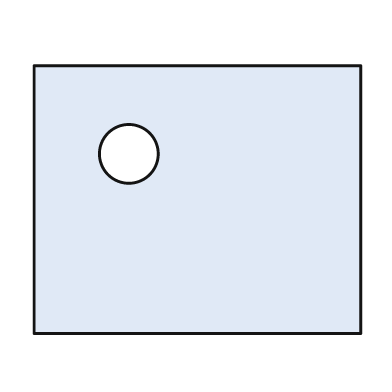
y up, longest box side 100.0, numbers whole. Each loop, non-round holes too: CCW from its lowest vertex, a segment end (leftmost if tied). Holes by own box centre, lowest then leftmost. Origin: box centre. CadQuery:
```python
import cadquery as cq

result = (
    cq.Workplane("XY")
    .moveTo(-50.0, -41.0)
    .lineTo(50.0, -41.0)
    .lineTo(50.0, 41.0)
    .lineTo(-50.0, 41.0)
    .close()
    .moveTo(-21.0, 14.0)
    .circle(9.0)
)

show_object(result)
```